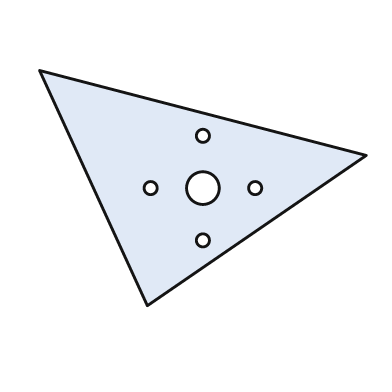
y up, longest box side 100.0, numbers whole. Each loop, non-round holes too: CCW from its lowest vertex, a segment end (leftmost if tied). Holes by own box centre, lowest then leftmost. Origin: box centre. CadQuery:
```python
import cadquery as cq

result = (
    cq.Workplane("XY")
    .moveTo(-17.0, -36.0)
    .lineTo(50.0, 10.0)
    .lineTo(-50.0, 36.0)
    .close()
    .moveTo(0.0, -16.0)
    .circle(2.0)
    .moveTo(-16.0, 0.0)
    .circle(2.0)
    .moveTo(0.0, 0.0)
    .circle(5.0)
    .moveTo(16.0, 0.0)
    .circle(2.0)
    .moveTo(0.0, 16.0)
    .circle(2.0)
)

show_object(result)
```